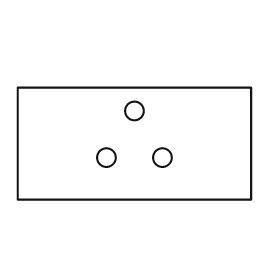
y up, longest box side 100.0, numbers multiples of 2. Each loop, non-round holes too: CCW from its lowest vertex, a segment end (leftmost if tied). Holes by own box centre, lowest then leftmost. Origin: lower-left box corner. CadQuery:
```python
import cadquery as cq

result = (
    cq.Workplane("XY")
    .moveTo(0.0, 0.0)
    .lineTo(100.0, 0.0)
    .lineTo(100.0, 48.0)
    .lineTo(0.0, 48.0)
    .close()
    .moveTo(38.0, 18.0)
    .circle(4.0)
    .moveTo(62.0, 18.0)
    .circle(4.0)
    .moveTo(50.0, 38.0)
    .circle(4.0)
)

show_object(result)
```